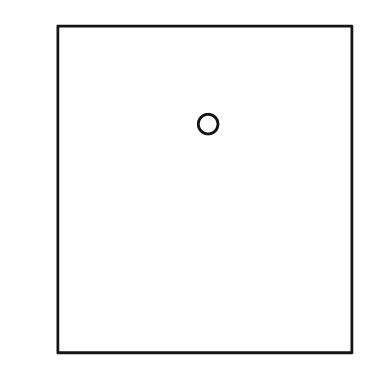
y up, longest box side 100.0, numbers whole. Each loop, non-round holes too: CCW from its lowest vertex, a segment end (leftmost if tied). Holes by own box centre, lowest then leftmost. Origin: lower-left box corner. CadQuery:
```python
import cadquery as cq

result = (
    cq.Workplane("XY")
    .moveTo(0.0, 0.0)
    .lineTo(90.0, 0.0)
    .lineTo(90.0, 100.0)
    .lineTo(0.0, 100.0)
    .close()
    .moveTo(46.0, 70.0)
    .circle(3.0)
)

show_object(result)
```